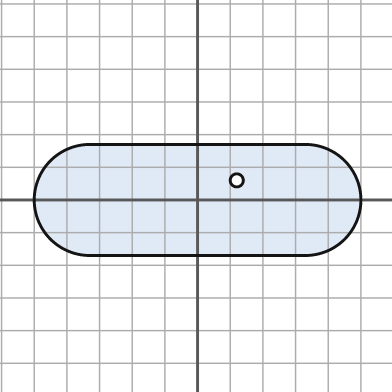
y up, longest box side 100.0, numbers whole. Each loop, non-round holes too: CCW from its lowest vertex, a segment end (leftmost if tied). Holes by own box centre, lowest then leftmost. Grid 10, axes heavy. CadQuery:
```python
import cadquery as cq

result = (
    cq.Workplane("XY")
    .moveTo(-33.0, -17.0)
    .lineTo(33.0, -17.0)
    .threePointArc((50.0, 0.0), (33.0, 17.0))
    .lineTo(-33.0, 17.0)
    .threePointArc((-50.0, 0.0), (-33.0, -17.0))
    .close()
    .moveTo(12.0, 6.0)
    .circle(2.0)
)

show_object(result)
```